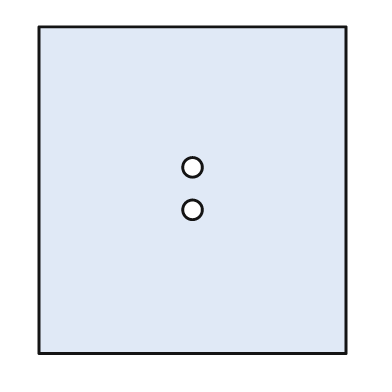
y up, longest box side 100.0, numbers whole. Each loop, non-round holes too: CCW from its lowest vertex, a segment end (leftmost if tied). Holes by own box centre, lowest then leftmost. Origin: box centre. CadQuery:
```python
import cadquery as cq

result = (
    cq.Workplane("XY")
    .moveTo(-47.0, -50.0)
    .lineTo(47.0, -50.0)
    .lineTo(47.0, 50.0)
    .lineTo(-47.0, 50.0)
    .close()
    .moveTo(0.0, -6.0)
    .circle(3.0)
    .moveTo(0.0, 7.0)
    .circle(3.0)
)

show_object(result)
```